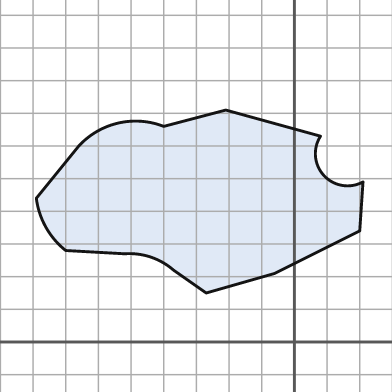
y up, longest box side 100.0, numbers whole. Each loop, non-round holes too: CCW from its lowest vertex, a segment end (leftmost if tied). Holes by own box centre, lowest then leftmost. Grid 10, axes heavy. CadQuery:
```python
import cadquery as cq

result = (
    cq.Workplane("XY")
    .moveTo(-27.0, 15.0)
    .lineTo(-6.0, 21.0)
    .lineTo(20.0, 34.0)
    .lineTo(21.0, 49.0)
    .threePointArc((9.0, 51.0), (8.0, 63.0))
    .lineTo(-21.0, 71.0)
    .lineTo(-40.0, 66.0)
    .threePointArc((-54.0, 67.0), (-66.0, 60.0))
    .lineTo(-79.0, 44.0)
    .threePointArc((-76.0, 35.0), (-70.0, 28.0))
    .lineTo(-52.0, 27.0)
    .threePointArc((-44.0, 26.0), (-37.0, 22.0))
    .close()
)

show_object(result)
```